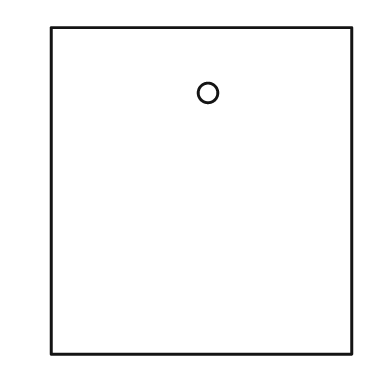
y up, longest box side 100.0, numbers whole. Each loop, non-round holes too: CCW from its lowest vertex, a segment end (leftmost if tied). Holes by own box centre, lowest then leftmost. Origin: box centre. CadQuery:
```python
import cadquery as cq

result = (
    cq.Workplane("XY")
    .moveTo(-46.0, -50.0)
    .lineTo(46.0, -50.0)
    .lineTo(46.0, 50.0)
    .lineTo(-46.0, 50.0)
    .close()
    .moveTo(2.0, 30.0)
    .circle(3.0)
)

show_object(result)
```